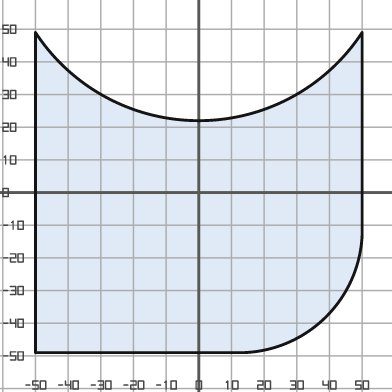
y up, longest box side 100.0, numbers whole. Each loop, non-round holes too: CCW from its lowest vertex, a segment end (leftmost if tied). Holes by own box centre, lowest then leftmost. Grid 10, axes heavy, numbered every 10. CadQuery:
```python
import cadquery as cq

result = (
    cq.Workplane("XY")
    .moveTo(-50.0, -49.0)
    .lineTo(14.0, -49.0)
    .threePointArc((39.0, -38.0), (50.0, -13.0))
    .lineTo(50.0, 49.0)
    .threePointArc((0.0, 22.0), (-50.0, 49.0))
    .close()
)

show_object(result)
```